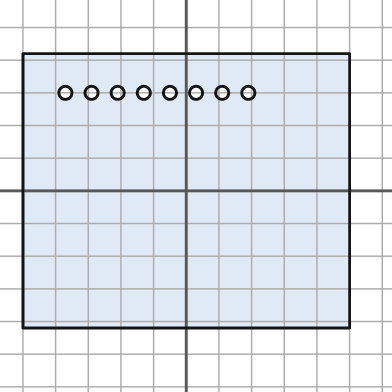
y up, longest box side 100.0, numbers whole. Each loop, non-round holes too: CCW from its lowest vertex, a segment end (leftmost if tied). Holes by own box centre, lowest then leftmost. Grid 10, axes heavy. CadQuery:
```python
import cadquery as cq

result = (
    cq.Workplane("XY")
    .moveTo(-50.0, -42.0)
    .lineTo(50.0, -42.0)
    .lineTo(50.0, 42.0)
    .lineTo(-50.0, 42.0)
    .close()
    .moveTo(-37.0, 30.0)
    .circle(2.0)
    .moveTo(-29.0, 30.0)
    .circle(2.0)
    .moveTo(-21.0, 30.0)
    .circle(2.0)
    .moveTo(-13.0, 30.0)
    .circle(2.0)
    .moveTo(-5.0, 30.0)
    .circle(2.0)
    .moveTo(3.0, 30.0)
    .circle(2.0)
    .moveTo(11.0, 30.0)
    .circle(2.0)
    .moveTo(19.0, 30.0)
    .circle(2.0)
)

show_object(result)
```